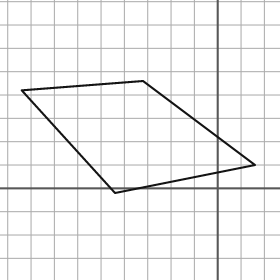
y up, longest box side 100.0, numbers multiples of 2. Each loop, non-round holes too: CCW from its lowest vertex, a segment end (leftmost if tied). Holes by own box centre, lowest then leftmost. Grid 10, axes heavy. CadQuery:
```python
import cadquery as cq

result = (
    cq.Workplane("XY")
    .moveTo(-44.0, -2.0)
    .lineTo(16.0, 10.0)
    .lineTo(-32.0, 46.0)
    .lineTo(-84.0, 42.0)
    .close()
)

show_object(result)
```